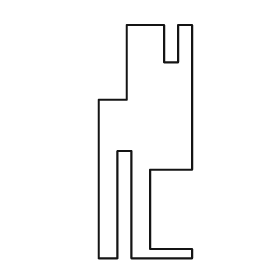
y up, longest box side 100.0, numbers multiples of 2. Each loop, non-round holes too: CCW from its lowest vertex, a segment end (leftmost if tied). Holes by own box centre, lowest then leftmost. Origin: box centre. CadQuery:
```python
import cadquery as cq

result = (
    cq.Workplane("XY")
    .moveTo(-20.0, -50.0)
    .lineTo(-12.0, -50.0)
    .lineTo(-12.0, -4.0)
    .lineTo(-6.0, -4.0)
    .lineTo(-6.0, -50.0)
    .lineTo(20.0, -50.0)
    .lineTo(20.0, -46.0)
    .lineTo(2.0, -46.0)
    .lineTo(2.0, -12.0)
    .lineTo(20.0, -12.0)
    .lineTo(20.0, 50.0)
    .lineTo(14.0, 50.0)
    .lineTo(14.0, 34.0)
    .lineTo(8.0, 34.0)
    .lineTo(8.0, 50.0)
    .lineTo(-8.0, 50.0)
    .lineTo(-8.0, 18.0)
    .lineTo(-20.0, 18.0)
    .close()
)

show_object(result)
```